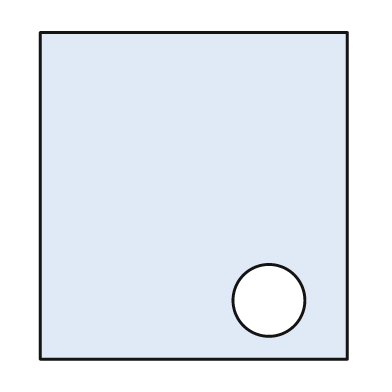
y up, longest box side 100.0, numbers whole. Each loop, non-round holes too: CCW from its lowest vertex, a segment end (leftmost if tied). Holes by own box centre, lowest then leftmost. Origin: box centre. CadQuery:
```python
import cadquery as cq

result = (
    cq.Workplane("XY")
    .moveTo(-47.0, -50.0)
    .lineTo(47.0, -50.0)
    .lineTo(47.0, 50.0)
    .lineTo(-47.0, 50.0)
    .close()
    .moveTo(23.0, -32.0)
    .circle(11.0)
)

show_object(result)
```